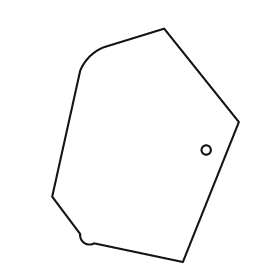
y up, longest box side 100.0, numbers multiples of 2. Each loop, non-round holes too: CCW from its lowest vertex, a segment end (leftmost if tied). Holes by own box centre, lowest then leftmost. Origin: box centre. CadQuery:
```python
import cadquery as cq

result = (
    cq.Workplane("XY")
    .moveTo(16.0, -50.0)
    .lineTo(40.0, 10.0)
    .lineTo(8.0, 50.0)
    .lineTo(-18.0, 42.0)
    .threePointArc((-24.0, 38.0), (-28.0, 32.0))
    .lineTo(-40.0, -22.0)
    .lineTo(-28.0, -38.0)
    .threePointArc((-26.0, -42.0), (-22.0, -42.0))
    .close()
    .moveTo(26.0, -2.0)
    .circle(2.0)
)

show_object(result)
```